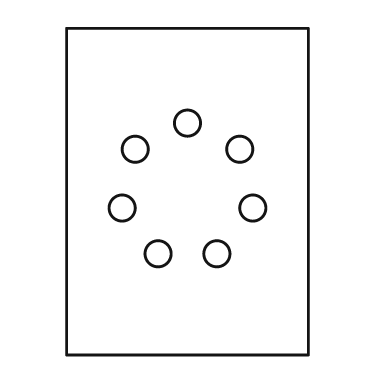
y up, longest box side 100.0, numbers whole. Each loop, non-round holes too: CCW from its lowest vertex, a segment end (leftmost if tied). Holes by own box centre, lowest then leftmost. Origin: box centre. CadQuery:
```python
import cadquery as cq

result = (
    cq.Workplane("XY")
    .moveTo(-37.0, -50.0)
    .lineTo(37.0, -50.0)
    .lineTo(37.0, 50.0)
    .lineTo(-37.0, 50.0)
    .close()
    .moveTo(-9.0, -19.0)
    .circle(4.0)
    .moveTo(9.0, -19.0)
    .circle(4.0)
    .moveTo(-20.0, -5.0)
    .circle(4.0)
    .moveTo(20.0, -5.0)
    .circle(4.0)
    .moveTo(-16.0, 13.0)
    .circle(4.0)
    .moveTo(16.0, 13.0)
    .circle(4.0)
    .moveTo(0.0, 21.0)
    .circle(4.0)
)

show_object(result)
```